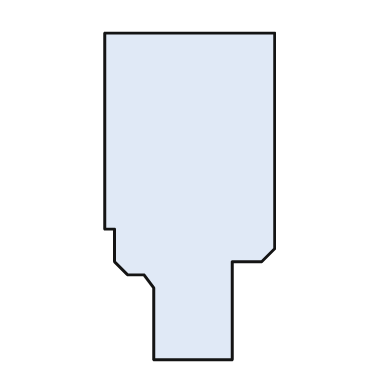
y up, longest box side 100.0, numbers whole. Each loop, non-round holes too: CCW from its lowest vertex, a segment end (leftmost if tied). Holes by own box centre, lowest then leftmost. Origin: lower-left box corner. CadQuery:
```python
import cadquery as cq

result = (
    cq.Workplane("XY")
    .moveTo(15.0, 0.0)
    .lineTo(39.0, 0.0)
    .lineTo(39.0, 30.0)
    .lineTo(48.0, 30.0)
    .lineTo(52.0, 34.0)
    .lineTo(52.0, 100.0)
    .lineTo(0.0, 100.0)
    .lineTo(0.0, 40.0)
    .lineTo(3.0, 40.0)
    .lineTo(3.0, 30.0)
    .lineTo(7.0, 26.0)
    .lineTo(12.0, 26.0)
    .lineTo(15.0, 22.0)
    .close()
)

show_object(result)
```